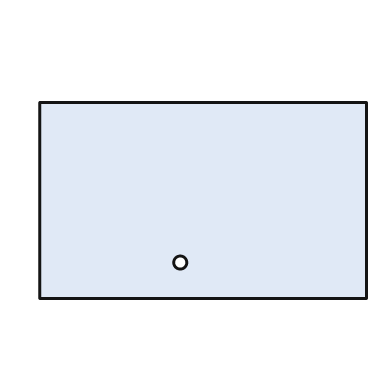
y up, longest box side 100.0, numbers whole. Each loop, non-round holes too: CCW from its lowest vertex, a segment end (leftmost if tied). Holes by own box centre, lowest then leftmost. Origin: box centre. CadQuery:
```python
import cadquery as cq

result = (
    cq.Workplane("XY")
    .moveTo(-50.0, -30.0)
    .lineTo(50.0, -30.0)
    .lineTo(50.0, 30.0)
    .lineTo(-50.0, 30.0)
    .close()
    .moveTo(-7.0, -19.0)
    .circle(2.0)
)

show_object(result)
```